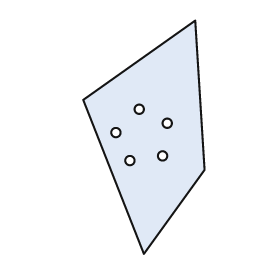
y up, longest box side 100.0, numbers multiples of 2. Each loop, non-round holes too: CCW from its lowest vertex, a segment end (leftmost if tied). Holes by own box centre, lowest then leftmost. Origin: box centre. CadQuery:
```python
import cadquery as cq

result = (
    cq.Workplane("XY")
    .moveTo(0.0, -50.0)
    .lineTo(26.0, -14.0)
    .lineTo(22.0, 50.0)
    .lineTo(-26.0, 16.0)
    .close()
    .moveTo(-6.0, -10.0)
    .circle(2.0)
    .moveTo(8.0, -8.0)
    .circle(2.0)
    .moveTo(-12.0, 2.0)
    .circle(2.0)
    .moveTo(10.0, 6.0)
    .circle(2.0)
    .moveTo(-2.0, 12.0)
    .circle(2.0)
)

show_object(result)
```